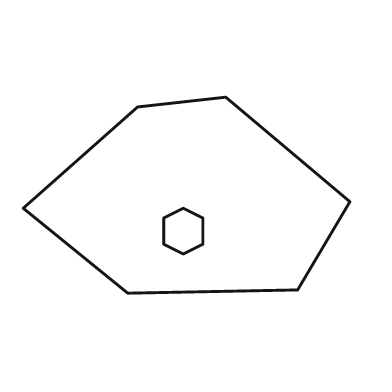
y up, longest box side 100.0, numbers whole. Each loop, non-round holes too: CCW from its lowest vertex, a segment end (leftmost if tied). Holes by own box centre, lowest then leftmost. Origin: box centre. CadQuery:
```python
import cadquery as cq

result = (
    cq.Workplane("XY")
    .moveTo(-18.0, -30.0)
    .lineTo(34.0, -29.0)
    .lineTo(50.0, -2.0)
    .lineTo(12.0, 30.0)
    .lineTo(-15.0, 27.0)
    .lineTo(-50.0, -4.0)
    .close()
    .moveTo(-1.0, -18.0)
    .lineTo(5.0, -15.0)
    .lineTo(5.0, -7.0)
    .lineTo(-1.0, -4.0)
    .lineTo(-7.0, -7.0)
    .lineTo(-7.0, -15.0)
    .close()
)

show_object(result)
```